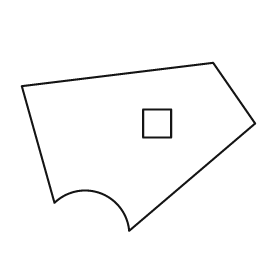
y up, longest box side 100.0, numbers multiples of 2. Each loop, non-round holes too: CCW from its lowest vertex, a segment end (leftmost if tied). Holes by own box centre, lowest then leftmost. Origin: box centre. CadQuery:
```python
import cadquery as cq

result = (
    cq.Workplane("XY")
    .moveTo(-4.0, -36.0)
    .lineTo(50.0, 10.0)
    .lineTo(32.0, 36.0)
    .lineTo(-50.0, 26.0)
    .lineTo(-36.0, -24.0)
    .threePointArc((-16.0, -20.0), (-4.0, -36.0))
    .close()
    .moveTo(2.0, 4.0)
    .lineTo(14.0, 4.0)
    .lineTo(14.0, 16.0)
    .lineTo(2.0, 16.0)
    .close()
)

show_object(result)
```